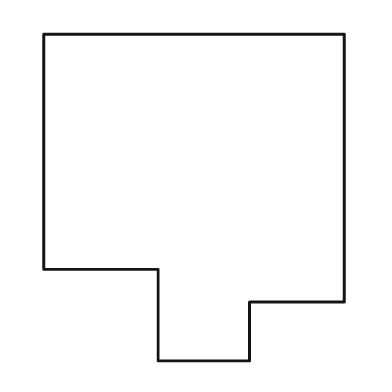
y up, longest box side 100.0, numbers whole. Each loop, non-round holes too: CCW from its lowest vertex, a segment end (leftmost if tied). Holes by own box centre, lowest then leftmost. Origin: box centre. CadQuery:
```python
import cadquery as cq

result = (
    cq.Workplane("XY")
    .moveTo(-11.0, -50.0)
    .lineTo(17.0, -50.0)
    .lineTo(17.0, -32.0)
    .lineTo(46.0, -32.0)
    .lineTo(46.0, 50.0)
    .lineTo(-46.0, 50.0)
    .lineTo(-46.0, -22.0)
    .lineTo(-11.0, -22.0)
    .close()
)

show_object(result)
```